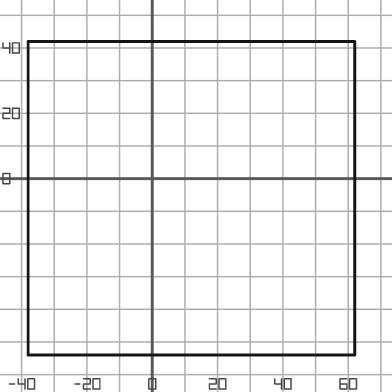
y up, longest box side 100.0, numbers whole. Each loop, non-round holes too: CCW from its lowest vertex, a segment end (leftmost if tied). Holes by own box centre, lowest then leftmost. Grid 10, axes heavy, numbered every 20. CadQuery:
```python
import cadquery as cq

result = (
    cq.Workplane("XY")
    .moveTo(-38.0, -54.0)
    .lineTo(62.0, -54.0)
    .lineTo(62.0, 42.0)
    .lineTo(-38.0, 42.0)
    .close()
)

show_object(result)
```